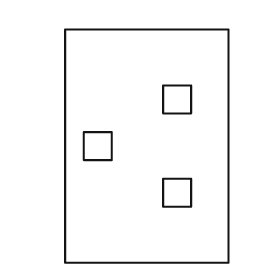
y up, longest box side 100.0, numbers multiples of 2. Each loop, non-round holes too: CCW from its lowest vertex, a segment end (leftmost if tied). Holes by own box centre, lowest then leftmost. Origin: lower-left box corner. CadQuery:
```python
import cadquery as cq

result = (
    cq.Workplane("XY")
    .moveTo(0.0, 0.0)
    .lineTo(70.0, 0.0)
    .lineTo(70.0, 100.0)
    .lineTo(0.0, 100.0)
    .close()
    .moveTo(42.0, 24.0)
    .lineTo(54.0, 24.0)
    .lineTo(54.0, 36.0)
    .lineTo(42.0, 36.0)
    .close()
    .moveTo(8.0, 44.0)
    .lineTo(20.0, 44.0)
    .lineTo(20.0, 56.0)
    .lineTo(8.0, 56.0)
    .close()
    .moveTo(42.0, 64.0)
    .lineTo(54.0, 64.0)
    .lineTo(54.0, 76.0)
    .lineTo(42.0, 76.0)
    .close()
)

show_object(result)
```